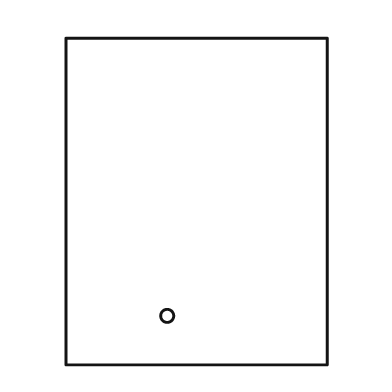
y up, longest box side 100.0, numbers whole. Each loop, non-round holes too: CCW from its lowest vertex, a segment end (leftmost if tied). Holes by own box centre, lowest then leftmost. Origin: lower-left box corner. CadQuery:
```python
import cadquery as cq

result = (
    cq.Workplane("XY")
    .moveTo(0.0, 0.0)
    .lineTo(80.0, 0.0)
    .lineTo(80.0, 100.0)
    .lineTo(0.0, 100.0)
    .close()
    .moveTo(31.0, 15.0)
    .circle(2.0)
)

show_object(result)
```